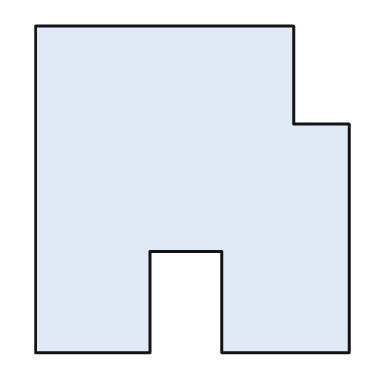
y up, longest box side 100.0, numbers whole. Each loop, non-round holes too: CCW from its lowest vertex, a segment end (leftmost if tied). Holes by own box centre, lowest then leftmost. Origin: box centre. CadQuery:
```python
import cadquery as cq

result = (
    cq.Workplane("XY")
    .moveTo(-48.0, -50.0)
    .lineTo(-13.0, -50.0)
    .lineTo(-13.0, -19.0)
    .lineTo(9.0, -19.0)
    .lineTo(9.0, -50.0)
    .lineTo(48.0, -50.0)
    .lineTo(48.0, 20.0)
    .lineTo(31.0, 20.0)
    .lineTo(31.0, 50.0)
    .lineTo(-48.0, 50.0)
    .close()
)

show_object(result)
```